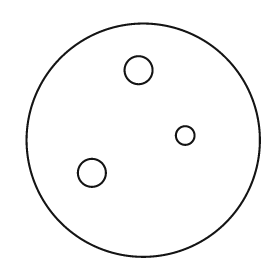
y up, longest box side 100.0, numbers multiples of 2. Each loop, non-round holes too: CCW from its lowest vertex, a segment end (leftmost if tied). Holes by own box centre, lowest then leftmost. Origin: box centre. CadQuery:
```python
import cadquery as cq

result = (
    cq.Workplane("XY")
    .moveTo(0.0, 0.0)
    .circle(50.0)
    .moveTo(-22.0, -14.0)
    .circle(6.0)
    .moveTo(18.0, 2.0)
    .circle(4.0)
    .moveTo(-2.0, 30.0)
    .circle(6.0)
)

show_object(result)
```